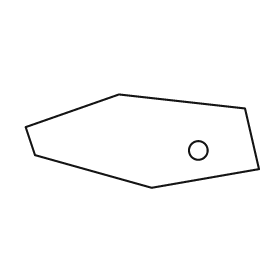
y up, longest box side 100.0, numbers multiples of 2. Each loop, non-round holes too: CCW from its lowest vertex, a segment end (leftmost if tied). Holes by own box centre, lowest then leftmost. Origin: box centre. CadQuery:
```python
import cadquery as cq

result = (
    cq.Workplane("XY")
    .moveTo(4.0, -20.0)
    .lineTo(50.0, -12.0)
    .lineTo(44.0, 14.0)
    .lineTo(-10.0, 20.0)
    .lineTo(-50.0, 6.0)
    .lineTo(-46.0, -6.0)
    .close()
    .moveTo(24.0, -4.0)
    .circle(4.0)
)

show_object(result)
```